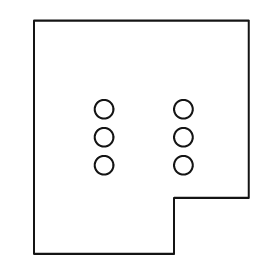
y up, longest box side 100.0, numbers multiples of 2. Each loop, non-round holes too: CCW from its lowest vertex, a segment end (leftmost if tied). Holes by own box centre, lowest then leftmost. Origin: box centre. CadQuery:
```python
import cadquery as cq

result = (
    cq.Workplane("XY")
    .moveTo(-46.0, -50.0)
    .lineTo(14.0, -50.0)
    .lineTo(14.0, -26.0)
    .lineTo(46.0, -26.0)
    .lineTo(46.0, 50.0)
    .lineTo(-46.0, 50.0)
    .close()
    .moveTo(-16.0, -12.0)
    .circle(4.0)
    .moveTo(18.0, -12.0)
    .circle(4.0)
    .moveTo(-16.0, 0.0)
    .circle(4.0)
    .moveTo(18.0, 0.0)
    .circle(4.0)
    .moveTo(-16.0, 12.0)
    .circle(4.0)
    .moveTo(18.0, 12.0)
    .circle(4.0)
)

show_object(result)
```